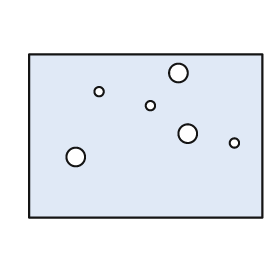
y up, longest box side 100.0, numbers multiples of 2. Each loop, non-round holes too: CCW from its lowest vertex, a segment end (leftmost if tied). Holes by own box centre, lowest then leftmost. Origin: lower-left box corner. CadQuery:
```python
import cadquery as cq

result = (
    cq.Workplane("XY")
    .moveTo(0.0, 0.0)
    .lineTo(100.0, 0.0)
    .lineTo(100.0, 70.0)
    .lineTo(0.0, 70.0)
    .close()
    .moveTo(20.0, 26.0)
    .circle(4.0)
    .moveTo(88.0, 32.0)
    .circle(2.0)
    .moveTo(68.0, 36.0)
    .circle(4.0)
    .moveTo(52.0, 48.0)
    .circle(2.0)
    .moveTo(30.0, 54.0)
    .circle(2.0)
    .moveTo(64.0, 62.0)
    .circle(4.0)
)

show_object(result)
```